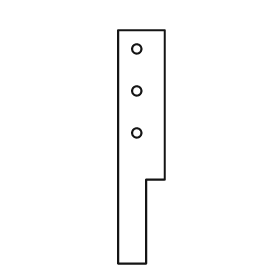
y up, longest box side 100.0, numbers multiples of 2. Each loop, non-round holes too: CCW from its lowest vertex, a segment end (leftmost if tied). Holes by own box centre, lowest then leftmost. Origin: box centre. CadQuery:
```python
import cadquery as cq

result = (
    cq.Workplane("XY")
    .moveTo(-10.0, -50.0)
    .lineTo(2.0, -50.0)
    .lineTo(2.0, -14.0)
    .lineTo(10.0, -14.0)
    .lineTo(10.0, 50.0)
    .lineTo(-10.0, 50.0)
    .close()
    .moveTo(-2.0, 6.0)
    .circle(2.0)
    .moveTo(-2.0, 24.0)
    .circle(2.0)
    .moveTo(-2.0, 42.0)
    .circle(2.0)
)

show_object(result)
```